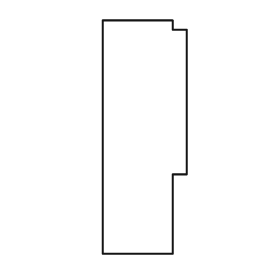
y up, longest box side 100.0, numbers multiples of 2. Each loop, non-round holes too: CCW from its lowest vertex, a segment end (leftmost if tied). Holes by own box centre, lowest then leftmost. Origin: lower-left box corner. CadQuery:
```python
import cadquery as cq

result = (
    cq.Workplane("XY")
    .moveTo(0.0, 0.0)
    .lineTo(30.0, 0.0)
    .lineTo(30.0, 34.0)
    .lineTo(36.0, 34.0)
    .lineTo(36.0, 96.0)
    .lineTo(30.0, 96.0)
    .lineTo(30.0, 100.0)
    .lineTo(0.0, 100.0)
    .close()
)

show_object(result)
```